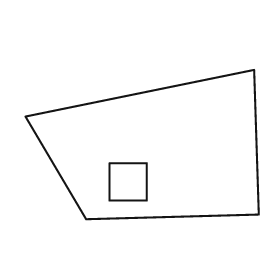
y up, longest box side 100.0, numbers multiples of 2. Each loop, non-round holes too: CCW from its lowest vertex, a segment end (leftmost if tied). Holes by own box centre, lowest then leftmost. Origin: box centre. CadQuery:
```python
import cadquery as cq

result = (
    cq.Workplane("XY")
    .moveTo(-24.0, -32.0)
    .lineTo(50.0, -30.0)
    .lineTo(48.0, 32.0)
    .lineTo(-50.0, 12.0)
    .close()
    .moveTo(-14.0, -24.0)
    .lineTo(2.0, -24.0)
    .lineTo(2.0, -8.0)
    .lineTo(-14.0, -8.0)
    .close()
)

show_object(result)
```